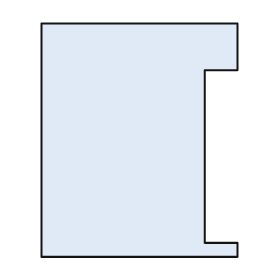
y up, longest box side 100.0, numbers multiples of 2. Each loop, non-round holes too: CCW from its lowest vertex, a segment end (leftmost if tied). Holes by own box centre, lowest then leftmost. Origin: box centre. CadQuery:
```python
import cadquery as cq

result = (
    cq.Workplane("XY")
    .moveTo(-42.0, -50.0)
    .lineTo(42.0, -50.0)
    .lineTo(42.0, -44.0)
    .lineTo(28.0, -44.0)
    .lineTo(28.0, 30.0)
    .lineTo(42.0, 30.0)
    .lineTo(42.0, 50.0)
    .lineTo(-42.0, 50.0)
    .close()
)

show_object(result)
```